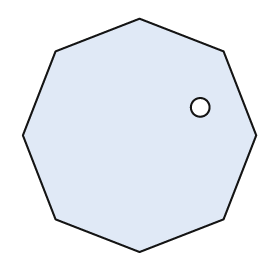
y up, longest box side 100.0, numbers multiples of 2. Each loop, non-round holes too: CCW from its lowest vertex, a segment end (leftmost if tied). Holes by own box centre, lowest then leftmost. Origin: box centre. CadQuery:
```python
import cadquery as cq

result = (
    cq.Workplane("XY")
    .moveTo(0.0, -50.0)
    .lineTo(36.0, -36.0)
    .lineTo(50.0, 0.0)
    .lineTo(36.0, 36.0)
    .lineTo(0.0, 50.0)
    .lineTo(-36.0, 36.0)
    .lineTo(-50.0, 0.0)
    .lineTo(-36.0, -36.0)
    .close()
    .moveTo(26.0, 12.0)
    .circle(4.0)
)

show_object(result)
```